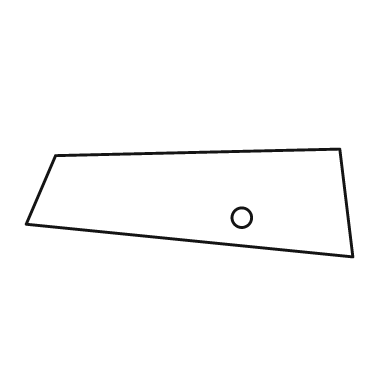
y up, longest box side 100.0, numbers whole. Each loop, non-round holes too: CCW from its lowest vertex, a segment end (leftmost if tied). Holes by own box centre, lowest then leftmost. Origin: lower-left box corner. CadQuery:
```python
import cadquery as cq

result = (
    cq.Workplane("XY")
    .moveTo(100.0, 0.0)
    .lineTo(96.0, 33.0)
    .lineTo(9.0, 31.0)
    .lineTo(0.0, 10.0)
    .close()
    .moveTo(66.0, 12.0)
    .circle(3.0)
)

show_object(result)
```